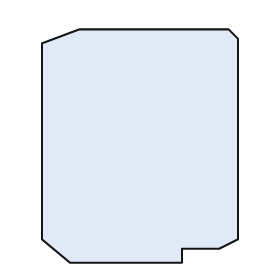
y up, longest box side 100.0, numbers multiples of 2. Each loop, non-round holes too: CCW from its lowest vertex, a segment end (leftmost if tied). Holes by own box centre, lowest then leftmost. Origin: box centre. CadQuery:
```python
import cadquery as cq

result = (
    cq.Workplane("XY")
    .moveTo(-30.0, -50.0)
    .lineTo(18.0, -50.0)
    .lineTo(18.0, -44.0)
    .lineTo(34.0, -44.0)
    .lineTo(42.0, -40.0)
    .lineTo(42.0, 46.0)
    .lineTo(38.0, 50.0)
    .lineTo(-26.0, 50.0)
    .lineTo(-42.0, 44.0)
    .lineTo(-42.0, -40.0)
    .close()
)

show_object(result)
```